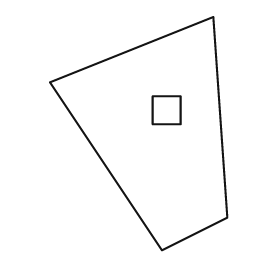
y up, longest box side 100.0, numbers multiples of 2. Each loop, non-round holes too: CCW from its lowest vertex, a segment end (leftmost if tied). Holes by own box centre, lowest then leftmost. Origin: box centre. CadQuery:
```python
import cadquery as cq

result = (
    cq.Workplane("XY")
    .moveTo(10.0, -50.0)
    .lineTo(38.0, -36.0)
    .lineTo(32.0, 50.0)
    .lineTo(-38.0, 22.0)
    .close()
    .moveTo(6.0, 4.0)
    .lineTo(18.0, 4.0)
    .lineTo(18.0, 16.0)
    .lineTo(6.0, 16.0)
    .close()
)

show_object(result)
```